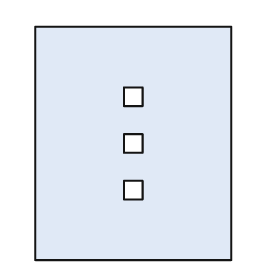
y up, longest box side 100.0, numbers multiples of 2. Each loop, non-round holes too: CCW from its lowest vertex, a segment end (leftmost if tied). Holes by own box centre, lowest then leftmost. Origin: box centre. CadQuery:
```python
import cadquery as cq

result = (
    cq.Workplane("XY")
    .moveTo(-42.0, -50.0)
    .lineTo(42.0, -50.0)
    .lineTo(42.0, 50.0)
    .lineTo(-42.0, 50.0)
    .close()
    .moveTo(-4.0, -24.0)
    .lineTo(4.0, -24.0)
    .lineTo(4.0, -16.0)
    .lineTo(-4.0, -16.0)
    .close()
    .moveTo(-4.0, -4.0)
    .lineTo(4.0, -4.0)
    .lineTo(4.0, 4.0)
    .lineTo(-4.0, 4.0)
    .close()
    .moveTo(-4.0, 16.0)
    .lineTo(4.0, 16.0)
    .lineTo(4.0, 24.0)
    .lineTo(-4.0, 24.0)
    .close()
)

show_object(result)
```